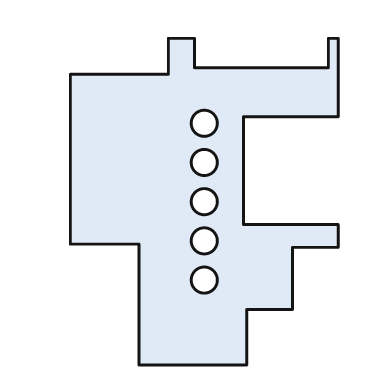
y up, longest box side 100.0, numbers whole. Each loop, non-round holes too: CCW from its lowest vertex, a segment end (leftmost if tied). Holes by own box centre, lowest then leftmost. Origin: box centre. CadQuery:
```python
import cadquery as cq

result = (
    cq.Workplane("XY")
    .moveTo(-20.0, -50.0)
    .lineTo(13.0, -50.0)
    .lineTo(13.0, -33.0)
    .lineTo(27.0, -33.0)
    .lineTo(27.0, -14.0)
    .lineTo(41.0, -14.0)
    .lineTo(41.0, -7.0)
    .lineTo(12.0, -7.0)
    .lineTo(12.0, 26.0)
    .lineTo(41.0, 26.0)
    .lineTo(41.0, 50.0)
    .lineTo(38.0, 50.0)
    .lineTo(38.0, 41.0)
    .lineTo(-3.0, 41.0)
    .lineTo(-3.0, 50.0)
    .lineTo(-11.0, 50.0)
    .lineTo(-11.0, 39.0)
    .lineTo(-41.0, 39.0)
    .lineTo(-41.0, -13.0)
    .lineTo(-20.0, -13.0)
    .close()
    .moveTo(0.0, -24.0)
    .circle(4.0)
    .moveTo(0.0, -12.0)
    .circle(4.0)
    .moveTo(0.0, 0.0)
    .circle(4.0)
    .moveTo(0.0, 12.0)
    .circle(4.0)
    .moveTo(0.0, 24.0)
    .circle(4.0)
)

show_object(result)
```